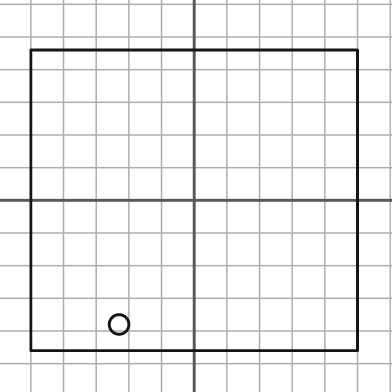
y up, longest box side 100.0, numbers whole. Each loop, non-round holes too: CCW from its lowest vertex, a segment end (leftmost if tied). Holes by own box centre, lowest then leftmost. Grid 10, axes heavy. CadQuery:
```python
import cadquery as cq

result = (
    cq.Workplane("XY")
    .moveTo(-50.0, -46.0)
    .lineTo(50.0, -46.0)
    .lineTo(50.0, 46.0)
    .lineTo(-50.0, 46.0)
    .close()
    .moveTo(-23.0, -38.0)
    .circle(3.0)
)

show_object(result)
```